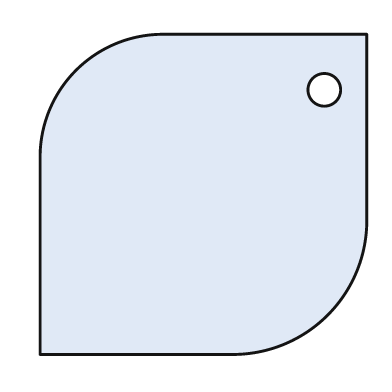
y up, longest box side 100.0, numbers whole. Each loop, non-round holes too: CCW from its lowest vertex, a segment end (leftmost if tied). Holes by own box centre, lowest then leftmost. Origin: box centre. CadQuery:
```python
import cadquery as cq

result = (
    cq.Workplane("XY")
    .moveTo(-50.0, -49.0)
    .lineTo(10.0, -49.0)
    .threePointArc((38.0, -37.0), (50.0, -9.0))
    .lineTo(50.0, 49.0)
    .lineTo(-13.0, 49.0)
    .threePointArc((-39.0, 38.0), (-50.0, 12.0))
    .close()
    .moveTo(37.0, 32.0)
    .circle(5.0)
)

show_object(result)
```